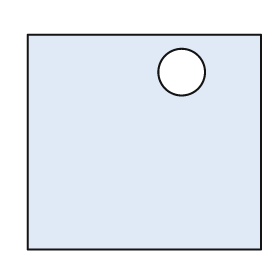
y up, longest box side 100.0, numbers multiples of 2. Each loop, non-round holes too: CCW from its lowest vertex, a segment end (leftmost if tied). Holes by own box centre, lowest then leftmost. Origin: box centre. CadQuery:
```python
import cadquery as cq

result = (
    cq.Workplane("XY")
    .moveTo(-50.0, -46.0)
    .lineTo(50.0, -46.0)
    .lineTo(50.0, 46.0)
    .lineTo(-50.0, 46.0)
    .close()
    .moveTo(16.0, 30.0)
    .circle(10.0)
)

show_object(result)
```